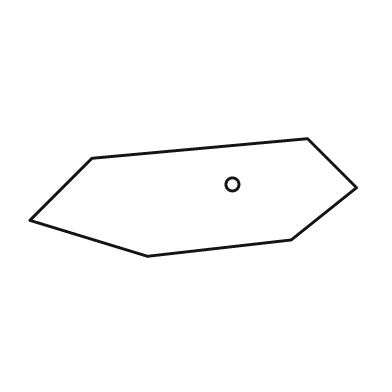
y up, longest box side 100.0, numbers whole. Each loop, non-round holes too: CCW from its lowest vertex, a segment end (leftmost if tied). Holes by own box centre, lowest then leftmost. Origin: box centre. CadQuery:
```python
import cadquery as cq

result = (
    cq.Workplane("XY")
    .moveTo(-14.0, -18.0)
    .lineTo(30.0, -13.0)
    .lineTo(50.0, 3.0)
    .lineTo(35.0, 18.0)
    .lineTo(-31.0, 12.0)
    .lineTo(-50.0, -7.0)
    .close()
    .moveTo(12.0, 4.0)
    .circle(2.0)
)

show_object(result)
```